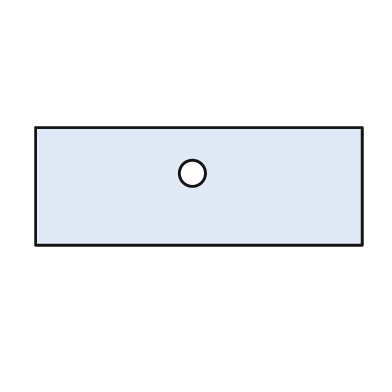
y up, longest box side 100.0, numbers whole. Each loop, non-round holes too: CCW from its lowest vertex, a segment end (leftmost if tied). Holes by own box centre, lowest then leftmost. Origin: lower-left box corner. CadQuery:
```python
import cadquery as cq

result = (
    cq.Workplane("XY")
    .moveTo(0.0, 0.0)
    .lineTo(100.0, 0.0)
    .lineTo(100.0, 36.0)
    .lineTo(0.0, 36.0)
    .close()
    .moveTo(48.0, 22.0)
    .circle(4.0)
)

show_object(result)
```